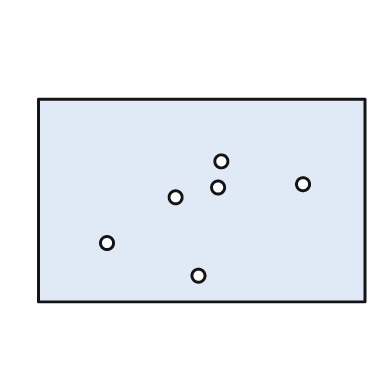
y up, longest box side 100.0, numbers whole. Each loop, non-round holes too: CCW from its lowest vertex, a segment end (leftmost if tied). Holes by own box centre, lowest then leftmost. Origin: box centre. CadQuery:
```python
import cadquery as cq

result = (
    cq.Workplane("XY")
    .moveTo(-50.0, -31.0)
    .lineTo(50.0, -31.0)
    .lineTo(50.0, 31.0)
    .lineTo(-50.0, 31.0)
    .close()
    .moveTo(-1.0, -23.0)
    .circle(2.0)
    .moveTo(-29.0, -13.0)
    .circle(2.0)
    .moveTo(-8.0, 1.0)
    .circle(2.0)
    .moveTo(5.0, 4.0)
    .circle(2.0)
    .moveTo(31.0, 5.0)
    .circle(2.0)
    .moveTo(6.0, 12.0)
    .circle(2.0)
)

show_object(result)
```